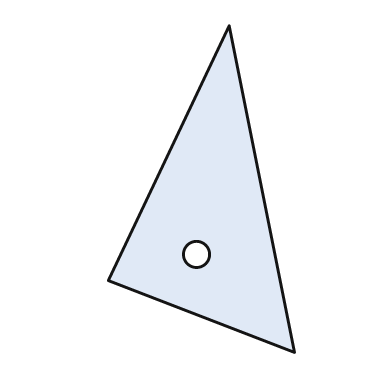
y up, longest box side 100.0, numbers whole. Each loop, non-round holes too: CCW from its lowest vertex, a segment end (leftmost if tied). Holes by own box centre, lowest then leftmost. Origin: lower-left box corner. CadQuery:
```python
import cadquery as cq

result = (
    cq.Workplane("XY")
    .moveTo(57.0, 0.0)
    .lineTo(37.0, 100.0)
    .lineTo(0.0, 22.0)
    .close()
    .moveTo(27.0, 30.0)
    .circle(4.0)
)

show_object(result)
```